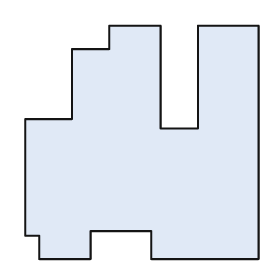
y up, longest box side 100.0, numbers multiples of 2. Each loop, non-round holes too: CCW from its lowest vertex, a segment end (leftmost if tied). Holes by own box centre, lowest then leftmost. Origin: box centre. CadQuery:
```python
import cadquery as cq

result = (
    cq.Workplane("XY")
    .moveTo(-44.0, -50.0)
    .lineTo(-22.0, -50.0)
    .lineTo(-22.0, -38.0)
    .lineTo(4.0, -38.0)
    .lineTo(4.0, -50.0)
    .lineTo(50.0, -50.0)
    .lineTo(50.0, 50.0)
    .lineTo(24.0, 50.0)
    .lineTo(24.0, 6.0)
    .lineTo(8.0, 6.0)
    .lineTo(8.0, 50.0)
    .lineTo(-14.0, 50.0)
    .lineTo(-14.0, 40.0)
    .lineTo(-30.0, 40.0)
    .lineTo(-30.0, 10.0)
    .lineTo(-50.0, 10.0)
    .lineTo(-50.0, -40.0)
    .lineTo(-44.0, -40.0)
    .close()
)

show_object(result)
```